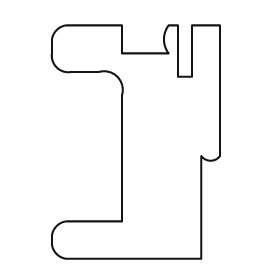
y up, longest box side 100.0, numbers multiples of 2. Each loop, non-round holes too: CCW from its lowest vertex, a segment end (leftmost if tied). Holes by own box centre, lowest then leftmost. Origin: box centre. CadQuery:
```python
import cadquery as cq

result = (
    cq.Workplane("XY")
    .moveTo(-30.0, -50.0)
    .lineTo(28.0, -50.0)
    .lineTo(28.0, -6.0)
    .threePointArc((32.0, -8.0), (36.0, -6.0))
    .lineTo(36.0, 50.0)
    .lineTo(24.0, 50.0)
    .lineTo(24.0, 28.0)
    .lineTo(18.0, 28.0)
    .lineTo(18.0, 50.0)
    .lineTo(14.0, 50.0)
    .threePointArc((12.0, 44.0), (14.0, 38.0))
    .lineTo(-6.0, 38.0)
    .lineTo(-6.0, 50.0)
    .lineTo(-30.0, 50.0)
    .threePointArc((-34.0, 48.0), (-36.0, 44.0))
    .lineTo(-36.0, 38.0)
    .threePointArc((-34.0, 32.0), (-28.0, 30.0))
    .lineTo(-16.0, 30.0)
    .threePointArc((-8.0, 28.0), (-6.0, 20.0))
    .lineTo(-6.0, -34.0)
    .lineTo(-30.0, -34.0)
    .threePointArc((-34.0, -36.0), (-36.0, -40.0))
    .lineTo(-36.0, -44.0)
    .threePointArc((-34.0, -48.0), (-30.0, -50.0))
    .close()
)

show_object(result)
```